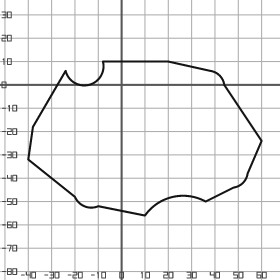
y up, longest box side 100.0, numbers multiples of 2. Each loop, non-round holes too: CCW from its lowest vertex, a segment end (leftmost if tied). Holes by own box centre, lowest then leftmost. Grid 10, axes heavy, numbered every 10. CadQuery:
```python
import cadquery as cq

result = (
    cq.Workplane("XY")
    .moveTo(10.0, -56.0)
    .threePointArc((22.0, -48.0), (36.0, -50.0))
    .lineTo(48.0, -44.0)
    .threePointArc((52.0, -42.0), (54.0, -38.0))
    .lineTo(60.0, -24.0)
    .lineTo(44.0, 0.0)
    .threePointArc((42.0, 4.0), (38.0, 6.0))
    .lineTo(20.0, 10.0)
    .lineTo(-8.0, 10.0)
    .threePointArc((-14.0, 0.0), (-24.0, 6.0))
    .lineTo(-38.0, -18.0)
    .lineTo(-40.0, -32.0)
    .lineTo(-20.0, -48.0)
    .threePointArc((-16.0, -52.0), (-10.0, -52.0))
    .close()
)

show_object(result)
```